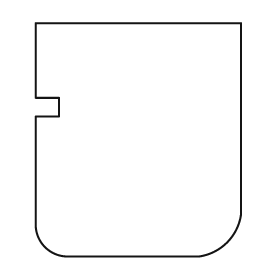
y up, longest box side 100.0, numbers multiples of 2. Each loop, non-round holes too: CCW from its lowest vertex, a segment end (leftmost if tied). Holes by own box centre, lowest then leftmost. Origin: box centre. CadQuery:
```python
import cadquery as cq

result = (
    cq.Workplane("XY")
    .moveTo(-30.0, -50.0)
    .lineTo(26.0, -50.0)
    .threePointArc((38.0, -44.0), (44.0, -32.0))
    .lineTo(44.0, 50.0)
    .lineTo(-44.0, 50.0)
    .lineTo(-44.0, 18.0)
    .lineTo(-34.0, 18.0)
    .lineTo(-34.0, 10.0)
    .lineTo(-44.0, 10.0)
    .lineTo(-44.0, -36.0)
    .threePointArc((-40.0, -46.0), (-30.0, -50.0))
    .close()
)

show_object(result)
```